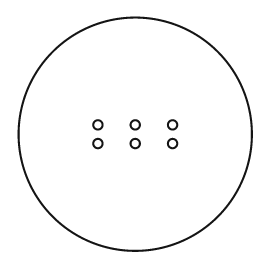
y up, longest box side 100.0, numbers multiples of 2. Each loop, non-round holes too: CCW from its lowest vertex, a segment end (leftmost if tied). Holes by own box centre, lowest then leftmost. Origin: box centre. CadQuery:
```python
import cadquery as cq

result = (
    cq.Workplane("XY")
    .moveTo(0.0, 0.0)
    .circle(50.0)
    .moveTo(-16.0, -4.0)
    .circle(2.0)
    .moveTo(0.0, -4.0)
    .circle(2.0)
    .moveTo(16.0, -4.0)
    .circle(2.0)
    .moveTo(-16.0, 4.0)
    .circle(2.0)
    .moveTo(0.0, 4.0)
    .circle(2.0)
    .moveTo(16.0, 4.0)
    .circle(2.0)
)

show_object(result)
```